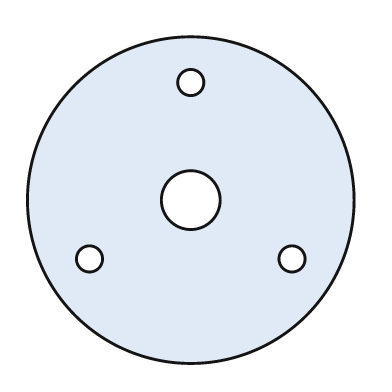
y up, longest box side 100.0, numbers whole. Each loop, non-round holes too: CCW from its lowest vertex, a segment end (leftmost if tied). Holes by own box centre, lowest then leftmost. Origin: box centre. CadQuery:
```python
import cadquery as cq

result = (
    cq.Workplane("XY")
    .moveTo(0.0, 0.0)
    .circle(50.0)
    .moveTo(-31.0, -18.0)
    .circle(4.0)
    .moveTo(31.0, -18.0)
    .circle(4.0)
    .moveTo(0.0, 0.0)
    .circle(9.0)
    .moveTo(0.0, 36.0)
    .circle(4.0)
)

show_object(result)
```